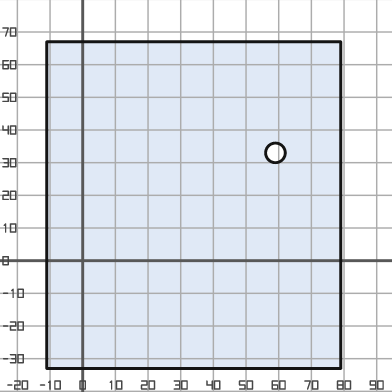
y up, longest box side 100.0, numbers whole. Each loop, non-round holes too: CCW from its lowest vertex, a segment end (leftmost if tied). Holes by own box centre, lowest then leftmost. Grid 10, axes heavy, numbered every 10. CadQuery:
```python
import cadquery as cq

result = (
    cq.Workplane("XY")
    .moveTo(-11.0, -33.0)
    .lineTo(79.0, -33.0)
    .lineTo(79.0, 67.0)
    .lineTo(-11.0, 67.0)
    .close()
    .moveTo(59.0, 33.0)
    .circle(3.0)
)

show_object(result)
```